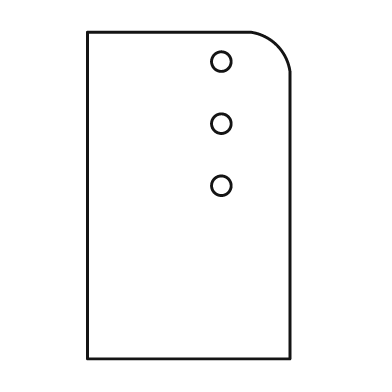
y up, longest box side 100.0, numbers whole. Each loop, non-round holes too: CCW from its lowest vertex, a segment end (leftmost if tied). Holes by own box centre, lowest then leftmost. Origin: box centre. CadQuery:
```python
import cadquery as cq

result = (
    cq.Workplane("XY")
    .moveTo(-31.0, -50.0)
    .lineTo(31.0, -50.0)
    .lineTo(31.0, 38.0)
    .threePointArc((27.0, 46.0), (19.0, 50.0))
    .lineTo(-31.0, 50.0)
    .close()
    .moveTo(10.0, 3.0)
    .circle(3.0)
    .moveTo(10.0, 22.0)
    .circle(3.0)
    .moveTo(10.0, 41.0)
    .circle(3.0)
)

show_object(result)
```